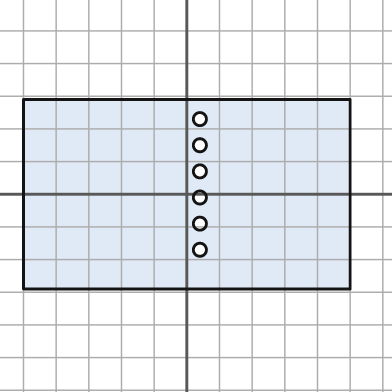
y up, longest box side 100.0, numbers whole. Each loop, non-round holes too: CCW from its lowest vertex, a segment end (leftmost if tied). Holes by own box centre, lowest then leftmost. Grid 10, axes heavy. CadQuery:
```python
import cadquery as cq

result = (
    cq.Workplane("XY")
    .moveTo(-50.0, -29.0)
    .lineTo(50.0, -29.0)
    .lineTo(50.0, 29.0)
    .lineTo(-50.0, 29.0)
    .close()
    .moveTo(4.0, -17.0)
    .circle(2.0)
    .moveTo(4.0, -9.0)
    .circle(2.0)
    .moveTo(4.0, -1.0)
    .circle(2.0)
    .moveTo(4.0, 7.0)
    .circle(2.0)
    .moveTo(4.0, 15.0)
    .circle(2.0)
    .moveTo(4.0, 23.0)
    .circle(2.0)
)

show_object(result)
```